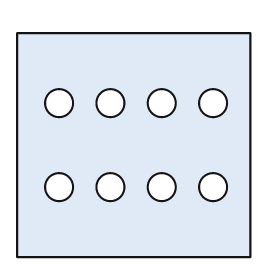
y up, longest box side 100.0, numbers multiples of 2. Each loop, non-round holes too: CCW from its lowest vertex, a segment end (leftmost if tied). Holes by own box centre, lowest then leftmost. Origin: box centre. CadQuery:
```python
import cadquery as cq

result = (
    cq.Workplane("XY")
    .moveTo(-50.0, -48.0)
    .lineTo(50.0, -48.0)
    .lineTo(50.0, 48.0)
    .lineTo(-50.0, 48.0)
    .close()
    .moveTo(-32.0, -18.0)
    .circle(6.0)
    .moveTo(-10.0, -18.0)
    .circle(6.0)
    .moveTo(12.0, -18.0)
    .circle(6.0)
    .moveTo(34.0, -18.0)
    .circle(6.0)
    .moveTo(-32.0, 18.0)
    .circle(6.0)
    .moveTo(-10.0, 18.0)
    .circle(6.0)
    .moveTo(12.0, 18.0)
    .circle(6.0)
    .moveTo(34.0, 18.0)
    .circle(6.0)
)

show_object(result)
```